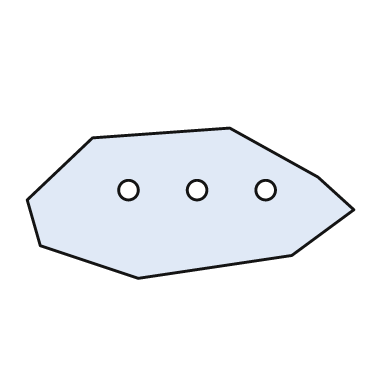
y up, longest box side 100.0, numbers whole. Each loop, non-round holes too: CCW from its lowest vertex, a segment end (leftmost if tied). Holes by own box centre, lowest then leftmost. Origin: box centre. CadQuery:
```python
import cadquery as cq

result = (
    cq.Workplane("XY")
    .moveTo(-16.0, -23.0)
    .lineTo(31.0, -16.0)
    .lineTo(50.0, -2.0)
    .lineTo(39.0, 8.0)
    .lineTo(12.0, 23.0)
    .lineTo(-30.0, 20.0)
    .lineTo(-50.0, 1.0)
    .lineTo(-46.0, -13.0)
    .close()
    .moveTo(-19.0, 4.0)
    .circle(3.0)
    .moveTo(2.0, 4.0)
    .circle(3.0)
    .moveTo(23.0, 4.0)
    .circle(3.0)
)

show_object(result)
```